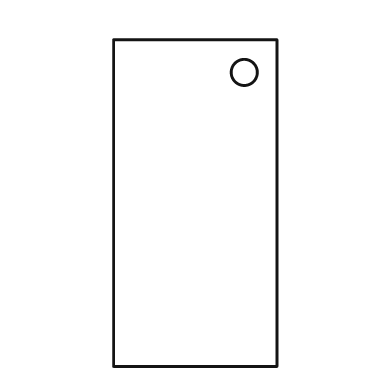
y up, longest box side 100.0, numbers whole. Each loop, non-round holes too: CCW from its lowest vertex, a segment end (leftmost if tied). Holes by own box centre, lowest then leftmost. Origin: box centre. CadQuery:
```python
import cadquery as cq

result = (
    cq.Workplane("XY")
    .moveTo(-25.0, -50.0)
    .lineTo(25.0, -50.0)
    .lineTo(25.0, 50.0)
    .lineTo(-25.0, 50.0)
    .close()
    .moveTo(15.0, 40.0)
    .circle(4.0)
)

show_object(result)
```